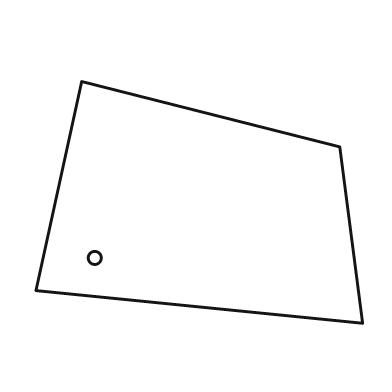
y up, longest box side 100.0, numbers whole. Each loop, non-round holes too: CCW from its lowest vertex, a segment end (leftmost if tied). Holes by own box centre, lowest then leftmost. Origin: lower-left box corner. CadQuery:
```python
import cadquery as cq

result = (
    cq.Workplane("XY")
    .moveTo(100.0, 0.0)
    .lineTo(93.0, 54.0)
    .lineTo(14.0, 74.0)
    .lineTo(0.0, 10.0)
    .close()
    .moveTo(18.0, 20.0)
    .circle(2.0)
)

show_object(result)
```